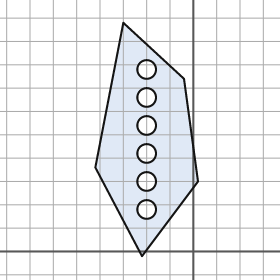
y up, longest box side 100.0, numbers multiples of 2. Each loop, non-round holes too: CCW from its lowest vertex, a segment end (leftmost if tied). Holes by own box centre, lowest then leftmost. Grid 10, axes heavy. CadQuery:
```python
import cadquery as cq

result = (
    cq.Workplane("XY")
    .moveTo(-22.0, -2.0)
    .lineTo(2.0, 30.0)
    .lineTo(-4.0, 74.0)
    .lineTo(-30.0, 98.0)
    .lineTo(-42.0, 36.0)
    .close()
    .moveTo(-20.0, 18.0)
    .circle(4.0)
    .moveTo(-20.0, 30.0)
    .circle(4.0)
    .moveTo(-20.0, 42.0)
    .circle(4.0)
    .moveTo(-20.0, 54.0)
    .circle(4.0)
    .moveTo(-20.0, 66.0)
    .circle(4.0)
    .moveTo(-20.0, 78.0)
    .circle(4.0)
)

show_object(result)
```